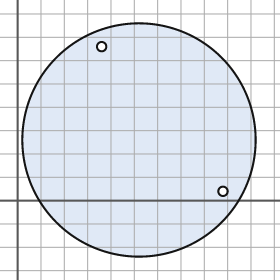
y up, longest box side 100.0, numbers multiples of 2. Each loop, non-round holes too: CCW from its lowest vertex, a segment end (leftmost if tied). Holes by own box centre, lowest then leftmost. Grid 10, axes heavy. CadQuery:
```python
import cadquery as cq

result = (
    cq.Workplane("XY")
    .moveTo(52.0, 26.0)
    .circle(50.0)
    .moveTo(88.0, 4.0)
    .circle(2.0)
    .moveTo(36.0, 66.0)
    .circle(2.0)
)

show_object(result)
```